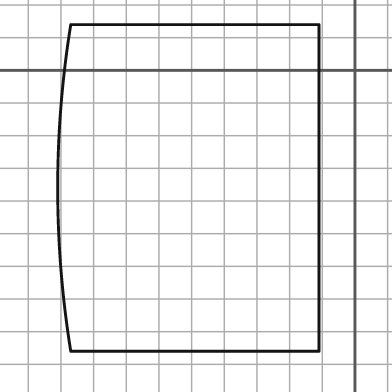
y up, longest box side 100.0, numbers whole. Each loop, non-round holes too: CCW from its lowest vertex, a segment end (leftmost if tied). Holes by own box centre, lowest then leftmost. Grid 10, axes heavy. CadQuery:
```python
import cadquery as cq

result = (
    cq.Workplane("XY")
    .moveTo(-87.0, -86.0)
    .lineTo(-11.0, -86.0)
    .lineTo(-11.0, 14.0)
    .lineTo(-87.0, 14.0)
    .threePointArc((-91.0, -36.0), (-87.0, -86.0))
    .close()
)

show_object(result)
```